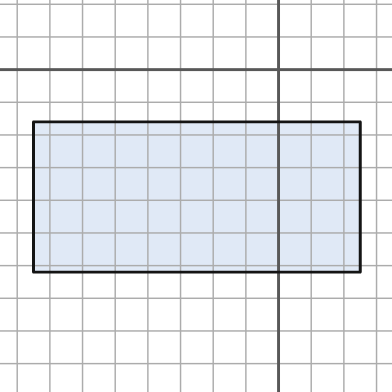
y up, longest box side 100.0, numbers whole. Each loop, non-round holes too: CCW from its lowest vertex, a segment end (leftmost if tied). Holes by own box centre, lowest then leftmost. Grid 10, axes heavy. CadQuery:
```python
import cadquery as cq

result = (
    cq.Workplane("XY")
    .moveTo(-75.0, -62.0)
    .lineTo(25.0, -62.0)
    .lineTo(25.0, -16.0)
    .lineTo(-75.0, -16.0)
    .close()
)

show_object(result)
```